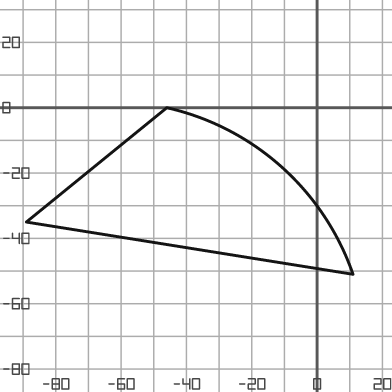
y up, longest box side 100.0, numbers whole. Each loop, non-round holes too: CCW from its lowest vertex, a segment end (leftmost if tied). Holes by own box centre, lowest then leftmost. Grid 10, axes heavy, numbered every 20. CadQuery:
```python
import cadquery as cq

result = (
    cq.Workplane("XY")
    .moveTo(11.0, -51.0)
    .threePointArc((-11.0, -18.0), (-46.0, 0.0))
    .lineTo(-89.0, -35.0)
    .close()
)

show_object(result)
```